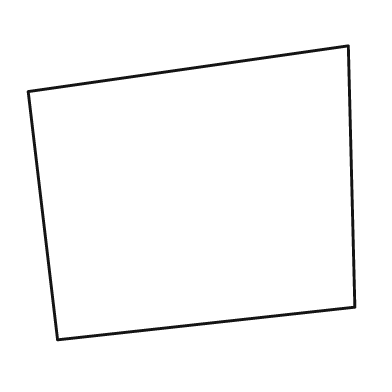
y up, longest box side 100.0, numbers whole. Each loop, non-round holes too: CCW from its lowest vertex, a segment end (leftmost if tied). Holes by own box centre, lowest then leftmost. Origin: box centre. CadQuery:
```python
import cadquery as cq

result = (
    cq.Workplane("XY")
    .moveTo(-41.0, -45.0)
    .lineTo(50.0, -35.0)
    .lineTo(48.0, 45.0)
    .lineTo(-50.0, 31.0)
    .close()
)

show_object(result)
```